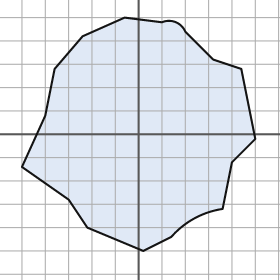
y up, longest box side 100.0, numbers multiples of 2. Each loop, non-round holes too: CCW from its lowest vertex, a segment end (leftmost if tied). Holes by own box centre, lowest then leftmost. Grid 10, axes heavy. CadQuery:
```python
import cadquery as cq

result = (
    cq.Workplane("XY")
    .moveTo(2.0, -50.0)
    .lineTo(14.0, -44.0)
    .threePointArc((24.0, -36.0), (36.0, -32.0))
    .lineTo(40.0, -12.0)
    .lineTo(50.0, -2.0)
    .lineTo(44.0, 28.0)
    .lineTo(32.0, 32.0)
    .lineTo(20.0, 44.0)
    .threePointArc((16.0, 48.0), (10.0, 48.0))
    .lineTo(-6.0, 50.0)
    .lineTo(-24.0, 42.0)
    .lineTo(-36.0, 28.0)
    .lineTo(-40.0, 8.0)
    .lineTo(-50.0, -14.0)
    .lineTo(-30.0, -28.0)
    .lineTo(-22.0, -40.0)
    .close()
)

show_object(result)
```